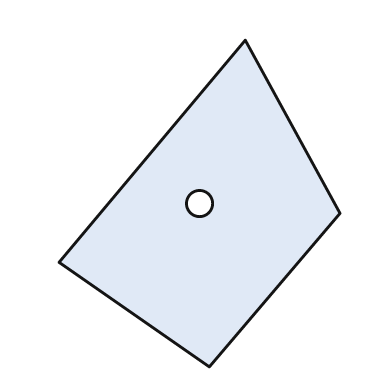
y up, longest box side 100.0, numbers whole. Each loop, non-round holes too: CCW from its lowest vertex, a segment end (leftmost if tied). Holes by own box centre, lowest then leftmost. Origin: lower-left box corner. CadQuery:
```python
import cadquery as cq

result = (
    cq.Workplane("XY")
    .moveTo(46.0, 0.0)
    .lineTo(86.0, 47.0)
    .lineTo(57.0, 100.0)
    .lineTo(0.0, 32.0)
    .close()
    .moveTo(43.0, 50.0)
    .circle(4.0)
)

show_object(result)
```